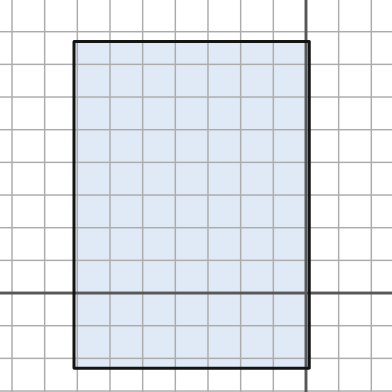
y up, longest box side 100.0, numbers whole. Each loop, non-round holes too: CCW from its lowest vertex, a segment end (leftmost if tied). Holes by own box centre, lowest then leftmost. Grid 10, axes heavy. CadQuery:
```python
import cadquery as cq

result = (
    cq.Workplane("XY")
    .moveTo(-71.0, -23.0)
    .lineTo(1.0, -23.0)
    .lineTo(1.0, 77.0)
    .lineTo(-71.0, 77.0)
    .close()
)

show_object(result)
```